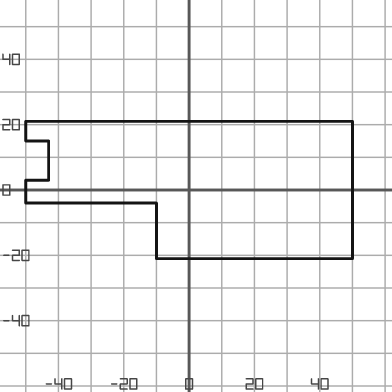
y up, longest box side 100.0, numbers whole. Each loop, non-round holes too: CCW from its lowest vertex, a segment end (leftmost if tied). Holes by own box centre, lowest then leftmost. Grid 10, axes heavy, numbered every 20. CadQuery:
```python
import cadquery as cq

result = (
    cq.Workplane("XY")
    .moveTo(-10.0, -21.0)
    .lineTo(50.0, -21.0)
    .lineTo(50.0, 21.0)
    .lineTo(-50.0, 21.0)
    .lineTo(-50.0, 15.0)
    .lineTo(-43.0, 15.0)
    .lineTo(-43.0, 3.0)
    .lineTo(-50.0, 3.0)
    .lineTo(-50.0, -4.0)
    .lineTo(-10.0, -4.0)
    .close()
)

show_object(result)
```